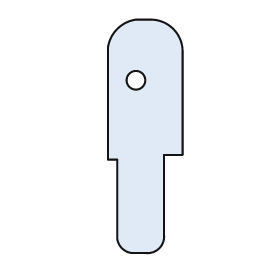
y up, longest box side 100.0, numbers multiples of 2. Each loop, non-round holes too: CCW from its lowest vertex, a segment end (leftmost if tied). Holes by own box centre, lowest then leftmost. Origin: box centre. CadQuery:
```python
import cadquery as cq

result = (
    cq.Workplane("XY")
    .moveTo(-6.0, -50.0)
    .lineTo(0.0, -50.0)
    .threePointArc((6.0, -48.0), (8.0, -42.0))
    .lineTo(8.0, -8.0)
    .lineTo(16.0, -8.0)
    .lineTo(16.0, 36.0)
    .threePointArc((12.0, 46.0), (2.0, 50.0))
    .lineTo(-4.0, 50.0)
    .threePointArc((-12.0, 46.0), (-16.0, 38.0))
    .lineTo(-16.0, -10.0)
    .lineTo(-12.0, -10.0)
    .lineTo(-12.0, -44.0)
    .threePointArc((-10.0, -48.0), (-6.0, -50.0))
    .close()
    .moveTo(-4.0, 24.0)
    .circle(4.0)
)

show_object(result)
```